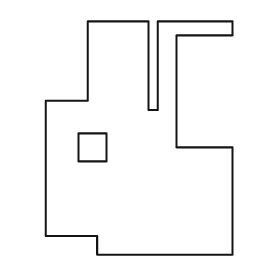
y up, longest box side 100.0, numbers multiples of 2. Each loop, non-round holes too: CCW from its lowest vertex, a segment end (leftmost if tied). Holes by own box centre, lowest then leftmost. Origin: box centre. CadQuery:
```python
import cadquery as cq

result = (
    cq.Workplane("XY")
    .moveTo(-18.0, -50.0)
    .lineTo(40.0, -50.0)
    .lineTo(40.0, -4.0)
    .lineTo(16.0, -4.0)
    .lineTo(16.0, 44.0)
    .lineTo(40.0, 44.0)
    .lineTo(40.0, 50.0)
    .lineTo(8.0, 50.0)
    .lineTo(8.0, 12.0)
    .lineTo(4.0, 12.0)
    .lineTo(4.0, 50.0)
    .lineTo(-22.0, 50.0)
    .lineTo(-22.0, 16.0)
    .lineTo(-40.0, 16.0)
    .lineTo(-40.0, -42.0)
    .lineTo(-18.0, -42.0)
    .close()
    .moveTo(-26.0, -10.0)
    .lineTo(-14.0, -10.0)
    .lineTo(-14.0, 2.0)
    .lineTo(-26.0, 2.0)
    .close()
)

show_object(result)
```